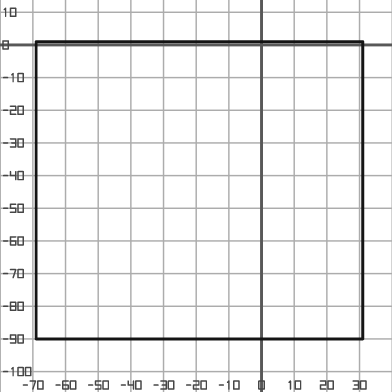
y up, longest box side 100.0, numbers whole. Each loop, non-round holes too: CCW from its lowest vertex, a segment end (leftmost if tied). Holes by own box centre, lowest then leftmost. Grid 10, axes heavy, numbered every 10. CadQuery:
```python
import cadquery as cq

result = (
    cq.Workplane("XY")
    .moveTo(-69.0, -90.0)
    .lineTo(31.0, -90.0)
    .lineTo(31.0, 1.0)
    .lineTo(-69.0, 1.0)
    .close()
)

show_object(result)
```